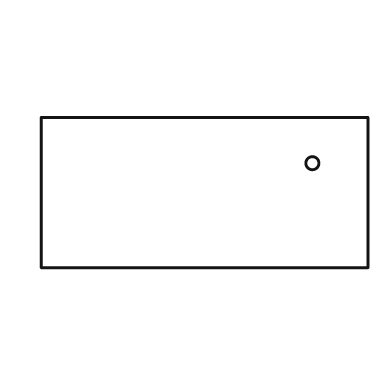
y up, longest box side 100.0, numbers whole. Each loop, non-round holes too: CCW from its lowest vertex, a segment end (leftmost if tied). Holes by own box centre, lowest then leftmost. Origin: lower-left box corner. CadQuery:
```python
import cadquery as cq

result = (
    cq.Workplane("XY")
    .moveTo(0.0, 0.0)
    .lineTo(100.0, 0.0)
    .lineTo(100.0, 46.0)
    .lineTo(0.0, 46.0)
    .close()
    .moveTo(83.0, 32.0)
    .circle(2.0)
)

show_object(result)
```